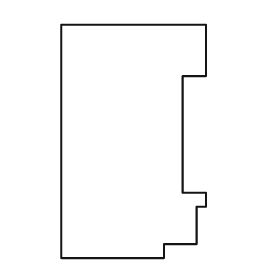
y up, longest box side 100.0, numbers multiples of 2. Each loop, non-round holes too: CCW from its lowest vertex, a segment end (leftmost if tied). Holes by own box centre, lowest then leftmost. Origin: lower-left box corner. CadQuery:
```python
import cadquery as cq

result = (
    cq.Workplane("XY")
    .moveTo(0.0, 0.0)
    .lineTo(44.0, 0.0)
    .lineTo(44.0, 6.0)
    .lineTo(58.0, 6.0)
    .lineTo(58.0, 22.0)
    .lineTo(62.0, 22.0)
    .lineTo(62.0, 28.0)
    .lineTo(52.0, 28.0)
    .lineTo(52.0, 78.0)
    .lineTo(62.0, 78.0)
    .lineTo(62.0, 100.0)
    .lineTo(0.0, 100.0)
    .close()
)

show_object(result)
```